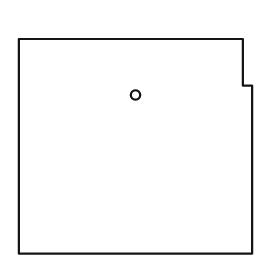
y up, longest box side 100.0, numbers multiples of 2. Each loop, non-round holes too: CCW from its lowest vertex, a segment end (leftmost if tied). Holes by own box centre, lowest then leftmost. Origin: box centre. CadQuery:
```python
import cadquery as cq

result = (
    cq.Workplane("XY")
    .moveTo(-50.0, -46.0)
    .lineTo(50.0, -46.0)
    .lineTo(50.0, 26.0)
    .lineTo(46.0, 26.0)
    .lineTo(46.0, 46.0)
    .lineTo(-50.0, 46.0)
    .close()
    .moveTo(0.0, 22.0)
    .circle(2.0)
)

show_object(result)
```